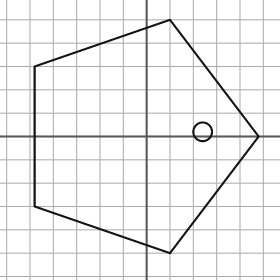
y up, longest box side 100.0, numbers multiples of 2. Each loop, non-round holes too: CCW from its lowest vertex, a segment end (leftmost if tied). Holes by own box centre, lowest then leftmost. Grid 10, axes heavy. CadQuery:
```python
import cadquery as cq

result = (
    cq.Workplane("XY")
    .moveTo(10.0, -50.0)
    .lineTo(48.0, 0.0)
    .lineTo(10.0, 50.0)
    .lineTo(-48.0, 30.0)
    .lineTo(-48.0, -30.0)
    .close()
    .moveTo(24.0, 2.0)
    .circle(4.0)
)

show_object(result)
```